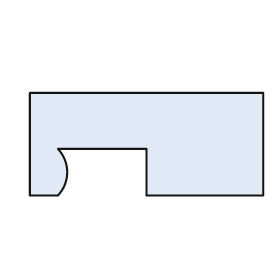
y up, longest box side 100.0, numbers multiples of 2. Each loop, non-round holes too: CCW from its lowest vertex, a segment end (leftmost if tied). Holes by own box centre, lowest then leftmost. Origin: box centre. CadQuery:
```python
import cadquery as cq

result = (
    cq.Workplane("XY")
    .moveTo(-50.0, -22.0)
    .lineTo(-38.0, -22.0)
    .threePointArc((-34.0, -12.0), (-38.0, -2.0))
    .lineTo(0.0, -2.0)
    .lineTo(0.0, -22.0)
    .lineTo(50.0, -22.0)
    .lineTo(50.0, 22.0)
    .lineTo(-50.0, 22.0)
    .close()
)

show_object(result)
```